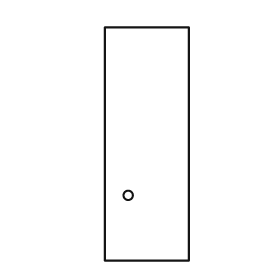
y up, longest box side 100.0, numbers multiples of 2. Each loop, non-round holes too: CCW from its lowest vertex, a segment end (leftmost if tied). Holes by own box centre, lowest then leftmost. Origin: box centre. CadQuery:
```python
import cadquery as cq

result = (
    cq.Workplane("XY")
    .moveTo(-18.0, -50.0)
    .lineTo(18.0, -50.0)
    .lineTo(18.0, 50.0)
    .lineTo(-18.0, 50.0)
    .close()
    .moveTo(-8.0, -22.0)
    .circle(2.0)
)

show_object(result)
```